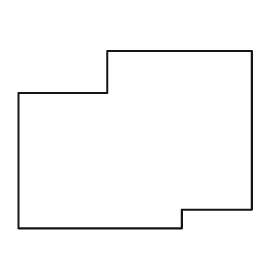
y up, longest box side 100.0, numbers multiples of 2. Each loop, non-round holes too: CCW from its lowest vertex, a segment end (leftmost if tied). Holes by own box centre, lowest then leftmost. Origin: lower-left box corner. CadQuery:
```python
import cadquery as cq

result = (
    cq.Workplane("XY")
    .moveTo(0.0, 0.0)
    .lineTo(70.0, 0.0)
    .lineTo(70.0, 8.0)
    .lineTo(100.0, 8.0)
    .lineTo(100.0, 76.0)
    .lineTo(38.0, 76.0)
    .lineTo(38.0, 58.0)
    .lineTo(0.0, 58.0)
    .close()
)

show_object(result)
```